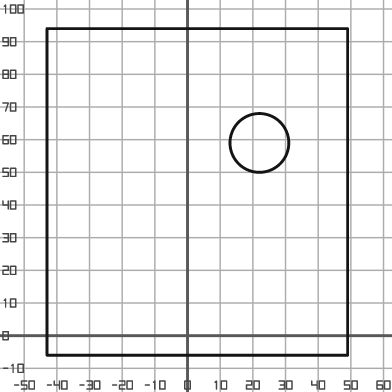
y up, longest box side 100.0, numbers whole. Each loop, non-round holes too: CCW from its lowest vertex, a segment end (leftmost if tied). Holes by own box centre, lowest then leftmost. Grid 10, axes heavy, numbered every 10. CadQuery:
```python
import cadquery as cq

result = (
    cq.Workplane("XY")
    .moveTo(-43.0, -6.0)
    .lineTo(49.0, -6.0)
    .lineTo(49.0, 94.0)
    .lineTo(-43.0, 94.0)
    .close()
    .moveTo(22.0, 59.0)
    .circle(9.0)
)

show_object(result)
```